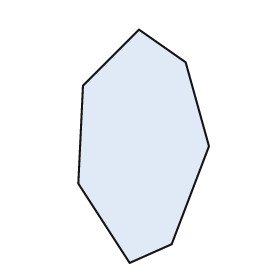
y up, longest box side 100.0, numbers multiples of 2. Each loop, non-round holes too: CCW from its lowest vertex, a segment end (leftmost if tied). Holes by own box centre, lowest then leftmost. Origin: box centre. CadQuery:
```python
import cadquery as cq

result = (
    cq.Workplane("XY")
    .moveTo(-6.0, -50.0)
    .lineTo(12.0, -42.0)
    .lineTo(28.0, 0.0)
    .lineTo(18.0, 36.0)
    .lineTo(-2.0, 50.0)
    .lineTo(-26.0, 26.0)
    .lineTo(-28.0, -16.0)
    .close()
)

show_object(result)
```